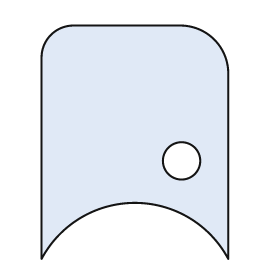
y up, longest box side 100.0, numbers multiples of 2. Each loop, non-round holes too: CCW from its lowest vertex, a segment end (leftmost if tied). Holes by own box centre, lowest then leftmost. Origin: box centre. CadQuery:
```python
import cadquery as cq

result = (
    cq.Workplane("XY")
    .moveTo(-40.0, -50.0)
    .threePointArc((0.0, -26.0), (40.0, -50.0))
    .lineTo(40.0, 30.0)
    .threePointArc((34.0, 44.0), (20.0, 50.0))
    .lineTo(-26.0, 50.0)
    .threePointArc((-36.0, 46.0), (-40.0, 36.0))
    .close()
    .moveTo(20.0, -8.0)
    .circle(8.0)
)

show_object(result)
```